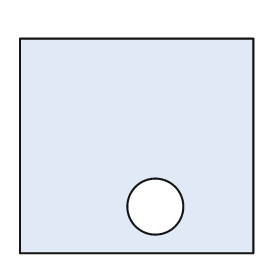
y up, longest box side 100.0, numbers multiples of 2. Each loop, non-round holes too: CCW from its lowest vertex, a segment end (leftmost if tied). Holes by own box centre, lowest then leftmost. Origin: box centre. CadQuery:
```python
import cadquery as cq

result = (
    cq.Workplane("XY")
    .moveTo(-50.0, -46.0)
    .lineTo(50.0, -46.0)
    .lineTo(50.0, 46.0)
    .lineTo(-50.0, 46.0)
    .close()
    .moveTo(8.0, -26.0)
    .circle(12.0)
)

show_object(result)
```